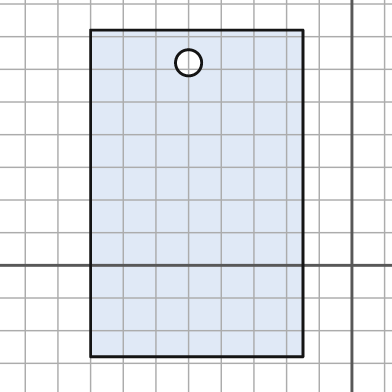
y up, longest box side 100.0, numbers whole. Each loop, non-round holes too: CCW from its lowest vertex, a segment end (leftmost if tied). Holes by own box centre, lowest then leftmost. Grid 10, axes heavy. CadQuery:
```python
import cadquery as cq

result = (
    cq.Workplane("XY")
    .moveTo(-80.0, -28.0)
    .lineTo(-15.0, -28.0)
    .lineTo(-15.0, 72.0)
    .lineTo(-80.0, 72.0)
    .close()
    .moveTo(-50.0, 62.0)
    .circle(4.0)
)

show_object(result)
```